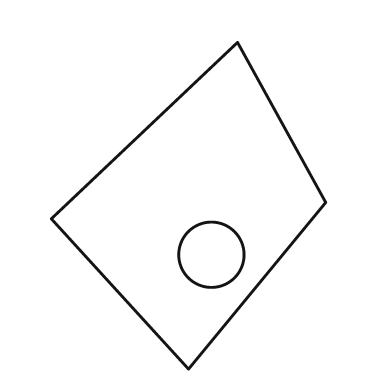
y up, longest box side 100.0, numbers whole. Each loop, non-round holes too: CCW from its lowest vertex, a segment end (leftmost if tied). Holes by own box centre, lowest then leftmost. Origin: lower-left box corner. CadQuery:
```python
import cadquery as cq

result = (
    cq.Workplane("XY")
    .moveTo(42.0, 0.0)
    .lineTo(84.0, 51.0)
    .lineTo(57.0, 100.0)
    .lineTo(0.0, 46.0)
    .close()
    .moveTo(49.0, 35.0)
    .circle(10.0)
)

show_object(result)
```